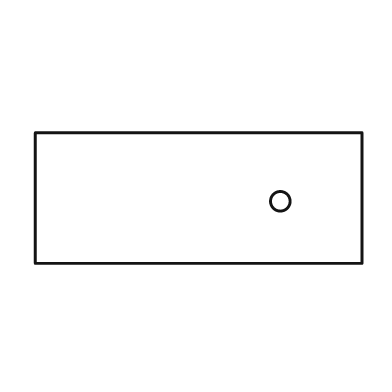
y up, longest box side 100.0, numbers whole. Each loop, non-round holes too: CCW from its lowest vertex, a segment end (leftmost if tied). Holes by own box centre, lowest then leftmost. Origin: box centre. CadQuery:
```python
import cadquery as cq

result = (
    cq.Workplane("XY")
    .moveTo(-50.0, -20.0)
    .lineTo(50.0, -20.0)
    .lineTo(50.0, 20.0)
    .lineTo(-50.0, 20.0)
    .close()
    .moveTo(25.0, -1.0)
    .circle(3.0)
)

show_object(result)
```